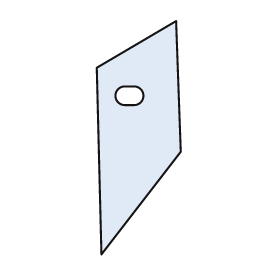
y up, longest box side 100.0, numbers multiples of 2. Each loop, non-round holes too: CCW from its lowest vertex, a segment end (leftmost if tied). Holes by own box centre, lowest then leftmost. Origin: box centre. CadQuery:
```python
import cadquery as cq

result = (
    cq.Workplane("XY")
    .moveTo(-16.0, -50.0)
    .lineTo(18.0, -6.0)
    .lineTo(16.0, 50.0)
    .lineTo(-18.0, 30.0)
    .close()
    .moveTo(-6.0, 14.0)
    .lineTo(-2.0, 14.0)
    .threePointArc((2.0, 18.0), (-2.0, 22.0))
    .lineTo(-6.0, 22.0)
    .threePointArc((-10.0, 18.0), (-6.0, 14.0))
    .close()
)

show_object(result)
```